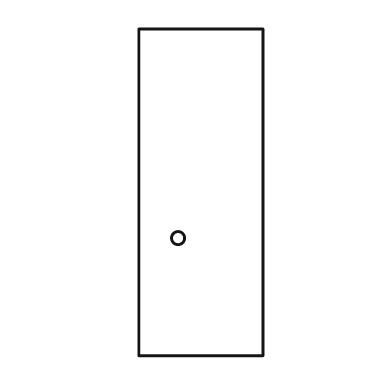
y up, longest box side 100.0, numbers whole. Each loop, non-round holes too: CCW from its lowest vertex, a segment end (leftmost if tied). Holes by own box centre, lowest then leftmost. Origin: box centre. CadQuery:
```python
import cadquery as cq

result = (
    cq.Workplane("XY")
    .moveTo(-19.0, -50.0)
    .lineTo(19.0, -50.0)
    .lineTo(19.0, 50.0)
    .lineTo(-19.0, 50.0)
    .close()
    .moveTo(-7.0, -14.0)
    .circle(2.0)
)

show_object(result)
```